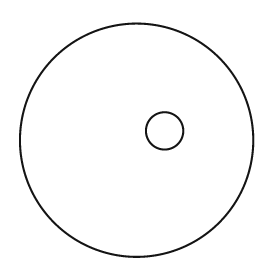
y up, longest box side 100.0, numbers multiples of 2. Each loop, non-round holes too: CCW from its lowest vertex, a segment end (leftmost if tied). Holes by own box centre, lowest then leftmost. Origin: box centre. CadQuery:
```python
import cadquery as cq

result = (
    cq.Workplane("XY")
    .moveTo(0.0, 0.0)
    .circle(50.0)
    .moveTo(12.0, 4.0)
    .circle(8.0)
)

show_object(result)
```